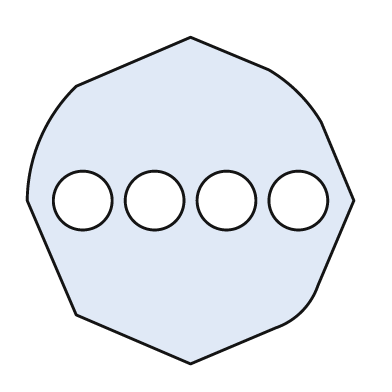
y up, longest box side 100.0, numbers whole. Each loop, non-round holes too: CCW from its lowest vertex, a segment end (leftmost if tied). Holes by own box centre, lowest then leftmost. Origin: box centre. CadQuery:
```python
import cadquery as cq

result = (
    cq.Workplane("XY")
    .moveTo(0.0, -50.0)
    .lineTo(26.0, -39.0)
    .threePointArc((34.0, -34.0), (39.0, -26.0))
    .lineTo(50.0, 0.0)
    .lineTo(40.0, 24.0)
    .threePointArc((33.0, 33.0), (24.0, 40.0))
    .lineTo(0.0, 50.0)
    .lineTo(-35.0, 35.0)
    .threePointArc((-46.0, 19.0), (-50.0, 0.0))
    .lineTo(-35.0, -35.0)
    .close()
    .moveTo(-33.0, 0.0)
    .circle(9.0)
    .moveTo(-11.0, 0.0)
    .circle(9.0)
    .moveTo(11.0, 0.0)
    .circle(9.0)
    .moveTo(33.0, 0.0)
    .circle(9.0)
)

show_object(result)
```